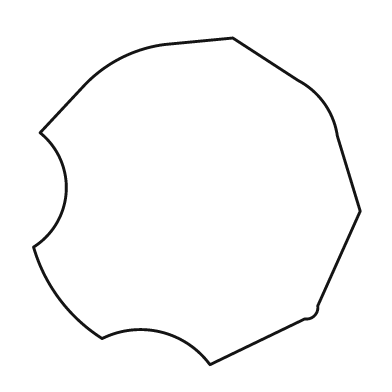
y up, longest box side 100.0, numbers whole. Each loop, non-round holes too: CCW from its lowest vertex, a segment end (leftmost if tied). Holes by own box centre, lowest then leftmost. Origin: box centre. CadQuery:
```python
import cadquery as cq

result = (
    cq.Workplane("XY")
    .moveTo(4.0, -50.0)
    .lineTo(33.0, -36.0)
    .threePointArc((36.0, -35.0), (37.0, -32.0))
    .lineTo(50.0, -3.0)
    .lineTo(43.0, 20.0)
    .threePointArc((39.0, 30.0), (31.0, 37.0))
    .lineTo(11.0, 50.0)
    .lineTo(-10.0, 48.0)
    .threePointArc((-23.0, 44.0), (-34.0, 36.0))
    .lineTo(-48.0, 21.0)
    .threePointArc((-40.0, 3.0), (-50.0, -14.0))
    .threePointArc((-42.0, -30.0), (-29.0, -42.0))
    .threePointArc((-11.0, -40.0), (4.0, -50.0))
    .close()
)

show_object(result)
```